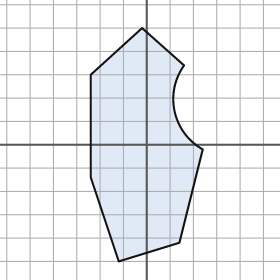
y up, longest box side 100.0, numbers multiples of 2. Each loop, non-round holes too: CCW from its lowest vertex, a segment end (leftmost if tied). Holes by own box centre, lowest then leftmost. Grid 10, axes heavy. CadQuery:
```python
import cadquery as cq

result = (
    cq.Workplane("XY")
    .moveTo(-12.0, -50.0)
    .lineTo(14.0, -42.0)
    .lineTo(24.0, -2.0)
    .threePointArc((12.0, 14.0), (16.0, 34.0))
    .lineTo(-2.0, 50.0)
    .lineTo(-24.0, 30.0)
    .lineTo(-24.0, -14.0)
    .close()
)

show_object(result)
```